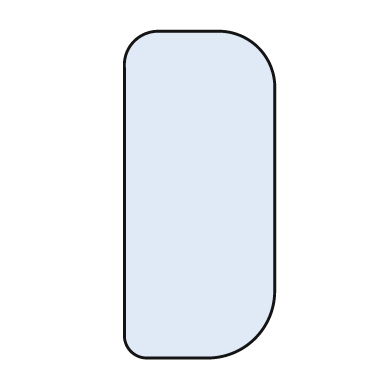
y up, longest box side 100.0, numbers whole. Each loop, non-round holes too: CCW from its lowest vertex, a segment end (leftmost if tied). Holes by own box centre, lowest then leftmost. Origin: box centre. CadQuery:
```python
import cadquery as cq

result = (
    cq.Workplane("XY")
    .moveTo(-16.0, -50.0)
    .lineTo(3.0, -50.0)
    .threePointArc((17.0, -44.0), (23.0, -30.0))
    .lineTo(23.0, 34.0)
    .threePointArc((18.0, 45.0), (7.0, 50.0))
    .lineTo(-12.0, 50.0)
    .threePointArc((-20.0, 47.0), (-23.0, 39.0))
    .lineTo(-23.0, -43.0)
    .threePointArc((-21.0, -48.0), (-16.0, -50.0))
    .close()
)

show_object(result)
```